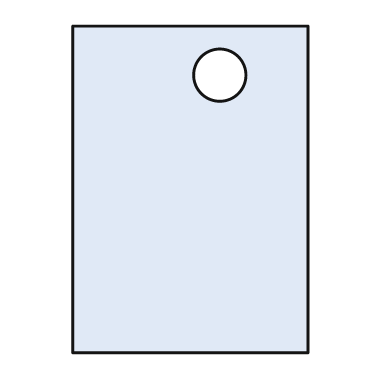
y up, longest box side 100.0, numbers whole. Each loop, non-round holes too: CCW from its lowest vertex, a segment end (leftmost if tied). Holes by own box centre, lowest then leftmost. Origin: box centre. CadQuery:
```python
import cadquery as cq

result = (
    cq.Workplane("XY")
    .moveTo(-36.0, -50.0)
    .lineTo(36.0, -50.0)
    .lineTo(36.0, 50.0)
    .lineTo(-36.0, 50.0)
    .close()
    .moveTo(9.0, 35.0)
    .circle(8.0)
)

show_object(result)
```